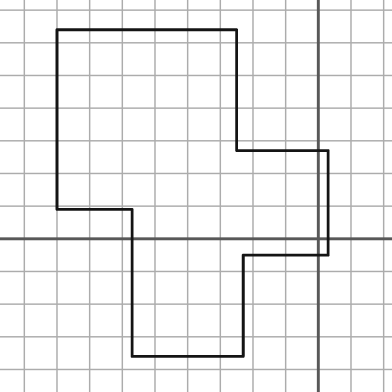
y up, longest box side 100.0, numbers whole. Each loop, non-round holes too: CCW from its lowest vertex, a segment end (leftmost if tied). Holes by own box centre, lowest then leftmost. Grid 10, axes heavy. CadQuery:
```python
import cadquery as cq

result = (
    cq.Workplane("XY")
    .moveTo(-57.0, -36.0)
    .lineTo(-23.0, -36.0)
    .lineTo(-23.0, -5.0)
    .lineTo(3.0, -5.0)
    .lineTo(3.0, 27.0)
    .lineTo(-25.0, 27.0)
    .lineTo(-25.0, 64.0)
    .lineTo(-80.0, 64.0)
    .lineTo(-80.0, 9.0)
    .lineTo(-57.0, 9.0)
    .close()
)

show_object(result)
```